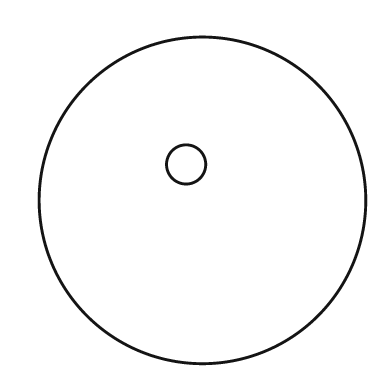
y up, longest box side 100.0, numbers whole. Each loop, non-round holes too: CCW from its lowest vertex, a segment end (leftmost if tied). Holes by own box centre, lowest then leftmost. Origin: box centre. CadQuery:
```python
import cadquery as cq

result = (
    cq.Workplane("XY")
    .moveTo(0.0, 0.0)
    .circle(50.0)
    .moveTo(-5.0, 11.0)
    .circle(6.0)
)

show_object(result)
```